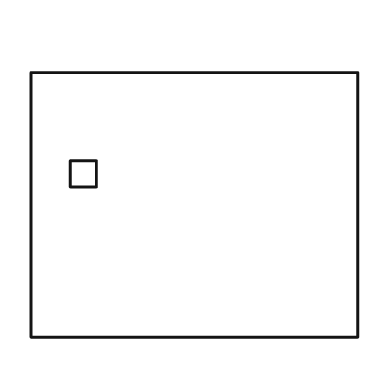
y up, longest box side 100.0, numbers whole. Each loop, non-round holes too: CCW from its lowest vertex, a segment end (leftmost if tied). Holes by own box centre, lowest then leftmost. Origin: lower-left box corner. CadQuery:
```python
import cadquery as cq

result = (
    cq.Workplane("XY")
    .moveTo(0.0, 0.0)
    .lineTo(100.0, 0.0)
    .lineTo(100.0, 81.0)
    .lineTo(0.0, 81.0)
    .close()
    .moveTo(12.0, 46.0)
    .lineTo(20.0, 46.0)
    .lineTo(20.0, 54.0)
    .lineTo(12.0, 54.0)
    .close()
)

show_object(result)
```